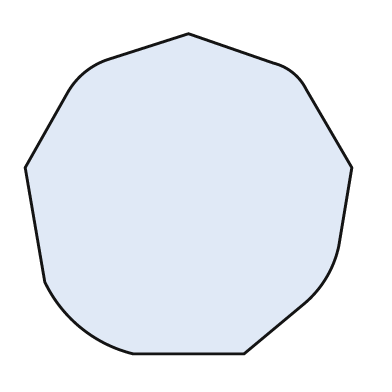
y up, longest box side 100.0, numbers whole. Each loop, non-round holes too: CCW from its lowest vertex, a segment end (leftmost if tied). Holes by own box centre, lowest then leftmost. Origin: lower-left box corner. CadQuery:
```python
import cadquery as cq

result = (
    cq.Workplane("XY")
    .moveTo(33.0, 0.0)
    .lineTo(67.0, 0.0)
    .lineTo(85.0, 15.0)
    .threePointArc((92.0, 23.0), (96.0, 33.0))
    .lineTo(100.0, 57.0)
    .lineTo(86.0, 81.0)
    .threePointArc((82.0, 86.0), (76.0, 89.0))
    .lineTo(50.0, 98.0)
    .lineTo(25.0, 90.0)
    .threePointArc((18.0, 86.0), (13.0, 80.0))
    .lineTo(0.0, 57.0)
    .lineTo(6.0, 22.0)
    .threePointArc((17.0, 8.0), (33.0, 0.0))
    .close()
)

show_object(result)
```